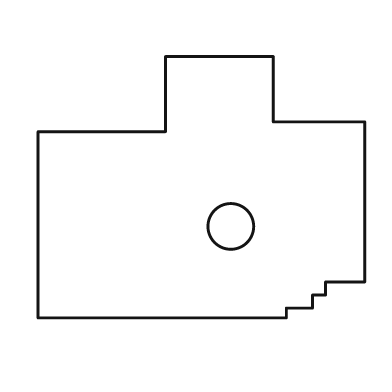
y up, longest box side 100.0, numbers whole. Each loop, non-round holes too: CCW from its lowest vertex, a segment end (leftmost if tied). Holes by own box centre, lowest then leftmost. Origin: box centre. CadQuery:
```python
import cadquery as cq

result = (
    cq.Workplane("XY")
    .moveTo(-50.0, -40.0)
    .lineTo(26.0, -40.0)
    .lineTo(26.0, -37.0)
    .lineTo(34.0, -37.0)
    .lineTo(34.0, -33.0)
    .lineTo(38.0, -33.0)
    .lineTo(38.0, -29.0)
    .lineTo(50.0, -29.0)
    .lineTo(50.0, 20.0)
    .lineTo(22.0, 20.0)
    .lineTo(22.0, 40.0)
    .lineTo(-11.0, 40.0)
    .lineTo(-11.0, 17.0)
    .lineTo(-50.0, 17.0)
    .close()
    .moveTo(9.0, -12.0)
    .circle(7.0)
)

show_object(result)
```